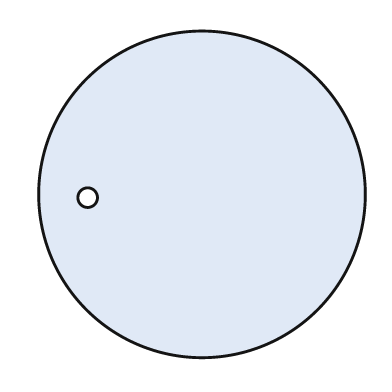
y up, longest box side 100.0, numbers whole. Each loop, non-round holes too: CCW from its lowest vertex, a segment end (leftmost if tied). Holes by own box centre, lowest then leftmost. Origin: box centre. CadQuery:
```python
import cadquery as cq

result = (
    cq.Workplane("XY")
    .moveTo(0.0, 0.0)
    .circle(50.0)
    .moveTo(-35.0, -1.0)
    .circle(3.0)
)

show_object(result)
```